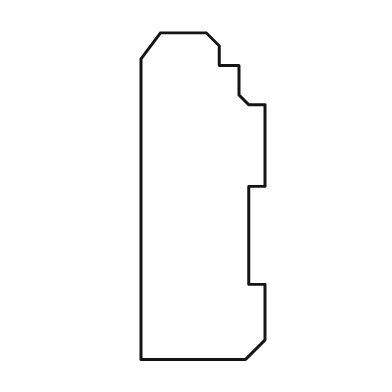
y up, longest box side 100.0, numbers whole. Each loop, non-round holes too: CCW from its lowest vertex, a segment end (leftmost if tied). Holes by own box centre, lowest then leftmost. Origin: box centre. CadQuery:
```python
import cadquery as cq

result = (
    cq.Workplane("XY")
    .moveTo(-19.0, -50.0)
    .lineTo(13.0, -50.0)
    .lineTo(19.0, -44.0)
    .lineTo(19.0, -27.0)
    .lineTo(14.0, -27.0)
    .lineTo(14.0, 3.0)
    .lineTo(19.0, 3.0)
    .lineTo(19.0, 28.0)
    .lineTo(14.0, 28.0)
    .lineTo(11.0, 31.0)
    .lineTo(11.0, 40.0)
    .lineTo(5.0, 40.0)
    .lineTo(5.0, 46.0)
    .lineTo(1.0, 50.0)
    .lineTo(-13.0, 50.0)
    .lineTo(-19.0, 42.0)
    .close()
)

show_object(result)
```